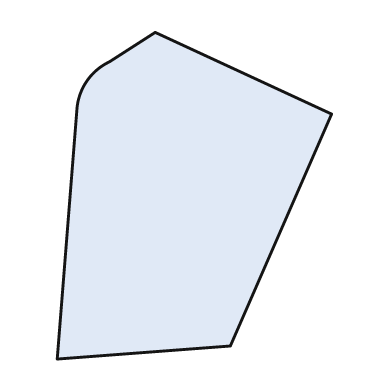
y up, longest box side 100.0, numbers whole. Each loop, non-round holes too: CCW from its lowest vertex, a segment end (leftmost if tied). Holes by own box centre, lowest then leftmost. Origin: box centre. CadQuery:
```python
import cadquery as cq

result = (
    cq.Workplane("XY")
    .moveTo(-42.0, -50.0)
    .lineTo(11.0, -46.0)
    .lineTo(42.0, 25.0)
    .lineTo(-12.0, 50.0)
    .lineTo(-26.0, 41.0)
    .threePointArc((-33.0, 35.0), (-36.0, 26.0))
    .close()
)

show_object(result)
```